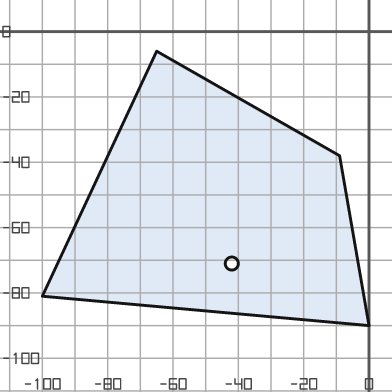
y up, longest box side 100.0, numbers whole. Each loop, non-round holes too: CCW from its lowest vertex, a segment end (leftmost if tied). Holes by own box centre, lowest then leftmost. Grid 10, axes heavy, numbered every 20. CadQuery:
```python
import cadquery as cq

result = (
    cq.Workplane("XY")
    .moveTo(0.0, -90.0)
    .lineTo(-9.0, -38.0)
    .lineTo(-65.0, -6.0)
    .lineTo(-100.0, -81.0)
    .close()
    .moveTo(-42.0, -71.0)
    .circle(2.0)
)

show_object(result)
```